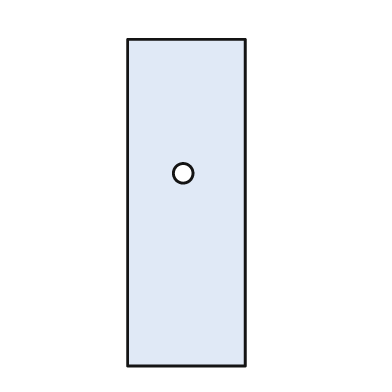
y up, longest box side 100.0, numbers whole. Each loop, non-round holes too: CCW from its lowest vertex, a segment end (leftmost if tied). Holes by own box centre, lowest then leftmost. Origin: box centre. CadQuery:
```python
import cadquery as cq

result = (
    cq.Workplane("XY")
    .moveTo(-18.0, -50.0)
    .lineTo(18.0, -50.0)
    .lineTo(18.0, 50.0)
    .lineTo(-18.0, 50.0)
    .close()
    .moveTo(-1.0, 9.0)
    .circle(3.0)
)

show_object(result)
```